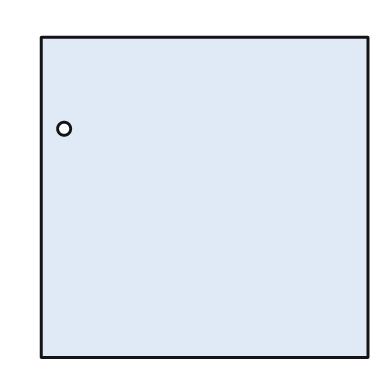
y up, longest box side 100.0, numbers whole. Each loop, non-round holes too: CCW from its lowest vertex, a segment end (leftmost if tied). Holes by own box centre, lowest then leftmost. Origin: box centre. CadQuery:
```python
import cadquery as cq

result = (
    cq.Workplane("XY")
    .moveTo(-50.0, -49.0)
    .lineTo(50.0, -49.0)
    .lineTo(50.0, 49.0)
    .lineTo(-50.0, 49.0)
    .close()
    .moveTo(-43.0, 21.0)
    .circle(2.0)
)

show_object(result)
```